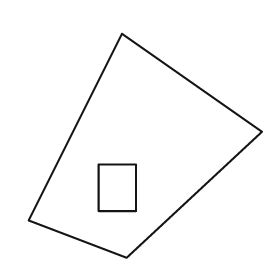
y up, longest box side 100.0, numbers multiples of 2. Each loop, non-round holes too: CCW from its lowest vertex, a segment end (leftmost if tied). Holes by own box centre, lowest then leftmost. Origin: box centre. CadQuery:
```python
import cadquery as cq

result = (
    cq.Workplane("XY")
    .moveTo(-8.0, -48.0)
    .lineTo(50.0, 6.0)
    .lineTo(-10.0, 48.0)
    .lineTo(-50.0, -32.0)
    .close()
    .moveTo(-20.0, -28.0)
    .lineTo(-4.0, -28.0)
    .lineTo(-4.0, -8.0)
    .lineTo(-20.0, -8.0)
    .close()
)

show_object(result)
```